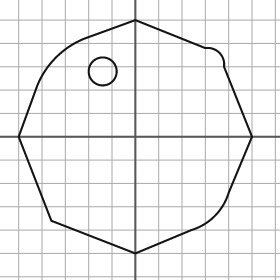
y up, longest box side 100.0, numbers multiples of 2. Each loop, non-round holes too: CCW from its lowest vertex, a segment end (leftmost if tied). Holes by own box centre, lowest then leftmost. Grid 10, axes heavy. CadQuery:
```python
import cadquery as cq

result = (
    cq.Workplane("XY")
    .moveTo(0.0, -50.0)
    .lineTo(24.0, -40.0)
    .threePointArc((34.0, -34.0), (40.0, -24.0))
    .lineTo(50.0, 0.0)
    .lineTo(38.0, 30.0)
    .threePointArc((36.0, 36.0), (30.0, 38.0))
    .lineTo(0.0, 50.0)
    .lineTo(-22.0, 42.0)
    .threePointArc((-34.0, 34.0), (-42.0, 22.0))
    .lineTo(-50.0, 0.0)
    .lineTo(-36.0, -36.0)
    .close()
    .moveTo(-14.0, 28.0)
    .circle(6.0)
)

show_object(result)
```